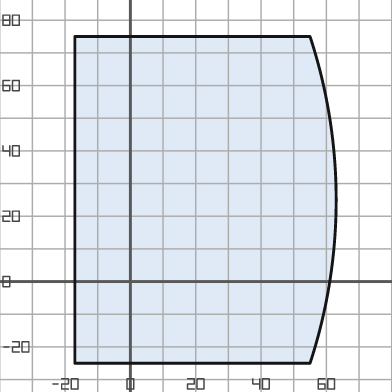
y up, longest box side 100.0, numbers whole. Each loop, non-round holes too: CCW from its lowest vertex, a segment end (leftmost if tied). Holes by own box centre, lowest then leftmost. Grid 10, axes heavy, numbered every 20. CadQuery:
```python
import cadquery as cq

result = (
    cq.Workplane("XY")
    .moveTo(-17.0, -25.0)
    .lineTo(55.0, -25.0)
    .threePointArc((63.0, 25.0), (55.0, 75.0))
    .lineTo(-17.0, 75.0)
    .close()
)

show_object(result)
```